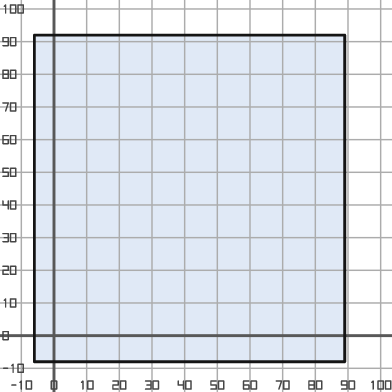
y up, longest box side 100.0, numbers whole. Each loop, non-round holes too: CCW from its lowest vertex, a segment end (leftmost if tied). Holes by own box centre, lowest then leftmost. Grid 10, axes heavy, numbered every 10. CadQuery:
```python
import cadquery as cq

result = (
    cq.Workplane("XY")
    .moveTo(-6.0, -8.0)
    .lineTo(89.0, -8.0)
    .lineTo(89.0, 92.0)
    .lineTo(-6.0, 92.0)
    .close()
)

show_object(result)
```